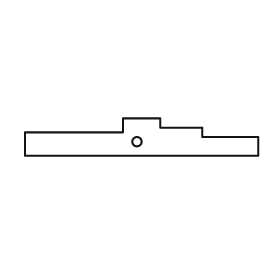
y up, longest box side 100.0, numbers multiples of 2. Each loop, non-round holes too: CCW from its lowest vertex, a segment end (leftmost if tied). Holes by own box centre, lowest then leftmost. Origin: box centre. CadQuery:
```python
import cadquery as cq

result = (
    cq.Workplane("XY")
    .moveTo(-50.0, -8.0)
    .lineTo(50.0, -8.0)
    .lineTo(50.0, 0.0)
    .lineTo(26.0, 0.0)
    .lineTo(26.0, 4.0)
    .lineTo(8.0, 4.0)
    .lineTo(8.0, 8.0)
    .lineTo(-8.0, 8.0)
    .lineTo(-8.0, 2.0)
    .lineTo(-50.0, 2.0)
    .close()
    .moveTo(-2.0, -2.0)
    .circle(2.0)
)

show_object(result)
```